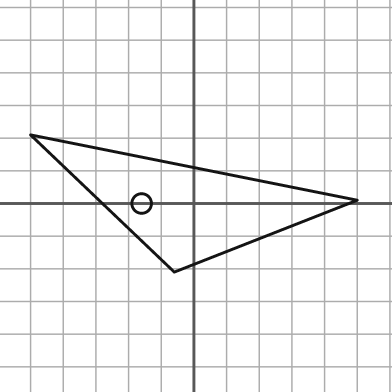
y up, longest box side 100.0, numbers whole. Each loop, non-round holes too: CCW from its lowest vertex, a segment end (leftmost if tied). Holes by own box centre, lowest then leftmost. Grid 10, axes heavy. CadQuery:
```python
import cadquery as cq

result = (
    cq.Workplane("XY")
    .moveTo(-6.0, -21.0)
    .lineTo(50.0, 1.0)
    .lineTo(-50.0, 21.0)
    .close()
    .moveTo(-16.0, 0.0)
    .circle(3.0)
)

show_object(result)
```